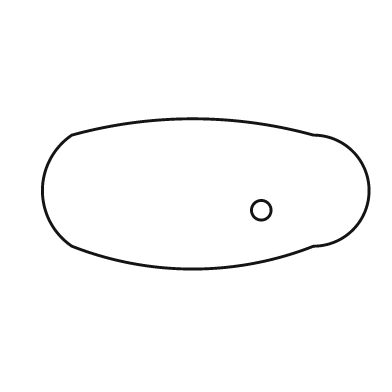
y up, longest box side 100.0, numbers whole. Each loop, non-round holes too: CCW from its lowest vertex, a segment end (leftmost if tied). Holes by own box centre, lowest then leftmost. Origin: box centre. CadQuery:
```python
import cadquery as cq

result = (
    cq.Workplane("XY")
    .moveTo(-41.0, -16.0)
    .threePointArc((-4.0, -23.0), (33.0, -16.0))
    .threePointArc((50.0, 1.0), (33.0, 18.0))
    .threePointArc((-4.0, 23.0), (-41.0, 18.0))
    .threePointArc((-50.0, 1.0), (-41.0, -16.0))
    .close()
    .moveTo(17.0, -5.0)
    .circle(3.0)
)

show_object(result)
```